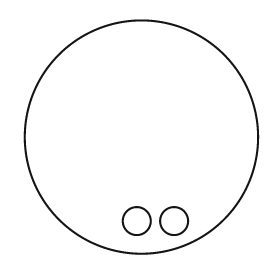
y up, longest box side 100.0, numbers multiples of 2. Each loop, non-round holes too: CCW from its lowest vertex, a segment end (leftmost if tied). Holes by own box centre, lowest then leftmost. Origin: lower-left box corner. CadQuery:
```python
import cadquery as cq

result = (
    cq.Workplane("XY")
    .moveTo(50.0, 50.0)
    .circle(50.0)
    .moveTo(48.0, 14.0)
    .circle(6.0)
    .moveTo(64.0, 14.0)
    .circle(6.0)
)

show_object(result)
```